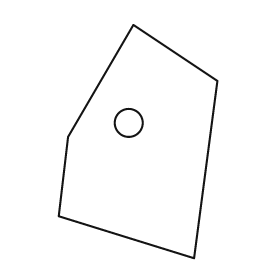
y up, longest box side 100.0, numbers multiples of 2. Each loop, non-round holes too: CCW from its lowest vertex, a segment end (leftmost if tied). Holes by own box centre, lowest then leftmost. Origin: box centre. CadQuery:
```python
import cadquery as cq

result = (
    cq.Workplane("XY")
    .moveTo(24.0, -50.0)
    .lineTo(34.0, 26.0)
    .lineTo(-2.0, 50.0)
    .lineTo(-30.0, 2.0)
    .lineTo(-34.0, -32.0)
    .close()
    .moveTo(-4.0, 8.0)
    .circle(6.0)
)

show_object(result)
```